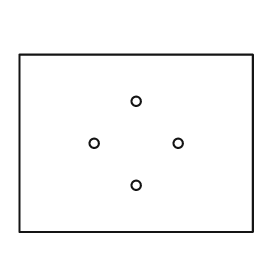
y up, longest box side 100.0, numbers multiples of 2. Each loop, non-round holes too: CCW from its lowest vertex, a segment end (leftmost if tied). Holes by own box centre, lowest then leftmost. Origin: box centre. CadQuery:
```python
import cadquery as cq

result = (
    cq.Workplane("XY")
    .moveTo(-50.0, -38.0)
    .lineTo(50.0, -38.0)
    .lineTo(50.0, 38.0)
    .lineTo(-50.0, 38.0)
    .close()
    .moveTo(0.0, -18.0)
    .circle(2.0)
    .moveTo(-18.0, 0.0)
    .circle(2.0)
    .moveTo(18.0, 0.0)
    .circle(2.0)
    .moveTo(0.0, 18.0)
    .circle(2.0)
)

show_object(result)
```